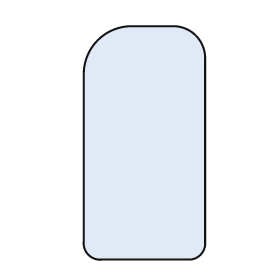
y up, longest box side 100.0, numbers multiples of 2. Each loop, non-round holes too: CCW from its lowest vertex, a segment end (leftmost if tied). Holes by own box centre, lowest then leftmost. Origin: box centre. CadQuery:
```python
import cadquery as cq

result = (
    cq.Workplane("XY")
    .moveTo(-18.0, -50.0)
    .lineTo(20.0, -50.0)
    .threePointArc((24.0, -48.0), (26.0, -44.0))
    .lineTo(26.0, 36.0)
    .threePointArc((22.0, 46.0), (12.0, 50.0))
    .lineTo(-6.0, 50.0)
    .threePointArc((-20.0, 44.0), (-26.0, 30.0))
    .lineTo(-26.0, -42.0)
    .threePointArc((-24.0, -48.0), (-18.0, -50.0))
    .close()
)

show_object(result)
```